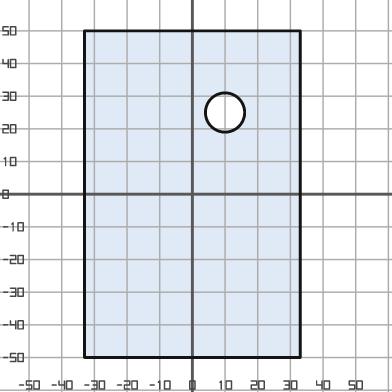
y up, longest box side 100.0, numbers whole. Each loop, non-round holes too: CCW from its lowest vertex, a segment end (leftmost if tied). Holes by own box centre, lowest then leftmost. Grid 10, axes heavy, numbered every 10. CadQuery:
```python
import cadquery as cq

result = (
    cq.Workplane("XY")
    .moveTo(-33.0, -50.0)
    .lineTo(33.0, -50.0)
    .lineTo(33.0, 50.0)
    .lineTo(-33.0, 50.0)
    .close()
    .moveTo(10.0, 25.0)
    .circle(6.0)
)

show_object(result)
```